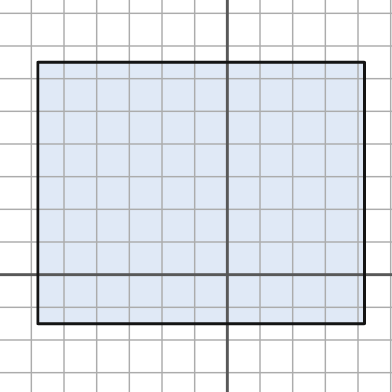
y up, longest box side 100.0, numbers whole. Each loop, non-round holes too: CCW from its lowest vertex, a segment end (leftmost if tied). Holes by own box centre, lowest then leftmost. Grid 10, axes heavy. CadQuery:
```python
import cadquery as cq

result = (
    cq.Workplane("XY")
    .moveTo(-58.0, -15.0)
    .lineTo(42.0, -15.0)
    .lineTo(42.0, 65.0)
    .lineTo(-58.0, 65.0)
    .close()
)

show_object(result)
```